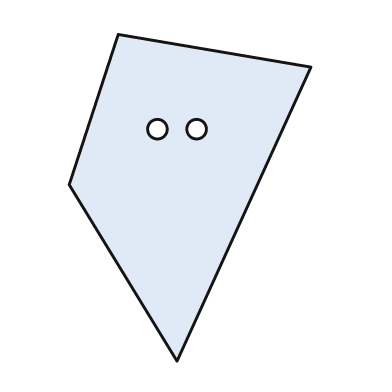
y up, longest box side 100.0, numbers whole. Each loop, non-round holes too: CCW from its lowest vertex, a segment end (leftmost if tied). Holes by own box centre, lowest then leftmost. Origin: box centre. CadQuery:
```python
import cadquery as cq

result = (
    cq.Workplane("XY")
    .moveTo(-4.0, -50.0)
    .lineTo(37.0, 40.0)
    .lineTo(-22.0, 50.0)
    .lineTo(-37.0, 4.0)
    .close()
    .moveTo(-10.0, 21.0)
    .circle(3.0)
    .moveTo(2.0, 21.0)
    .circle(3.0)
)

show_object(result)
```